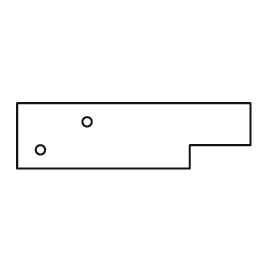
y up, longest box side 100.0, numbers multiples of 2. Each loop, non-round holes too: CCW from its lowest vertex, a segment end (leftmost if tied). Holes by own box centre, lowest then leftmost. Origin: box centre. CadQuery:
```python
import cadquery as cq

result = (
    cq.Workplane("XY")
    .moveTo(-50.0, -14.0)
    .lineTo(24.0, -14.0)
    .lineTo(24.0, -4.0)
    .lineTo(50.0, -4.0)
    .lineTo(50.0, 14.0)
    .lineTo(-50.0, 14.0)
    .close()
    .moveTo(-40.0, -6.0)
    .circle(2.0)
    .moveTo(-20.0, 6.0)
    .circle(2.0)
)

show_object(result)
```